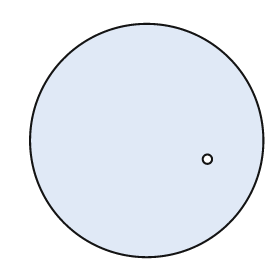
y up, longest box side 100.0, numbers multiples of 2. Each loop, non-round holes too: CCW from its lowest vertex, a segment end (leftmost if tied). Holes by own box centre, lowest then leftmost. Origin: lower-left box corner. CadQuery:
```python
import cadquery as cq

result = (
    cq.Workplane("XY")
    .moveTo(50.0, 50.0)
    .circle(50.0)
    .moveTo(76.0, 42.0)
    .circle(2.0)
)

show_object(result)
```